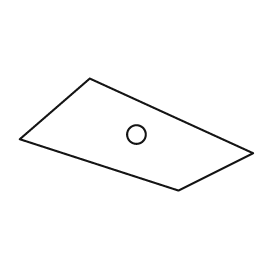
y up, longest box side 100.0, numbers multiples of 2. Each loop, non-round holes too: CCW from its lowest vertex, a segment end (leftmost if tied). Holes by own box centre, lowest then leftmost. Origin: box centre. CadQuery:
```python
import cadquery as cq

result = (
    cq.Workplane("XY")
    .moveTo(18.0, -24.0)
    .lineTo(50.0, -8.0)
    .lineTo(-20.0, 24.0)
    .lineTo(-50.0, -2.0)
    .close()
    .moveTo(0.0, 0.0)
    .circle(4.0)
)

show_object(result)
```